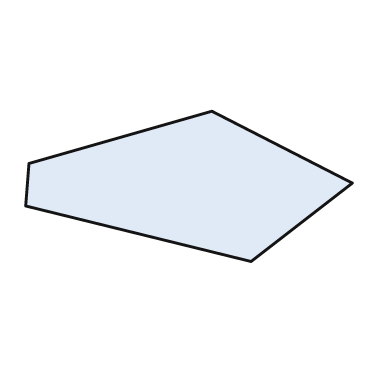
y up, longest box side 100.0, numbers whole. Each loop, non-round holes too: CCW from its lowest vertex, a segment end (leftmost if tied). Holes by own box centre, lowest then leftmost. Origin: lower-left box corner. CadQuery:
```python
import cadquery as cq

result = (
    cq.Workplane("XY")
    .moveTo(69.0, 0.0)
    .lineTo(100.0, 24.0)
    .lineTo(57.0, 46.0)
    .lineTo(1.0, 30.0)
    .lineTo(0.0, 17.0)
    .close()
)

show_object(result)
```